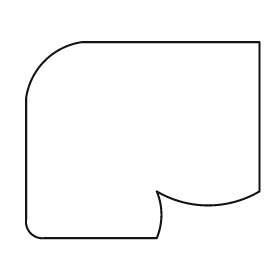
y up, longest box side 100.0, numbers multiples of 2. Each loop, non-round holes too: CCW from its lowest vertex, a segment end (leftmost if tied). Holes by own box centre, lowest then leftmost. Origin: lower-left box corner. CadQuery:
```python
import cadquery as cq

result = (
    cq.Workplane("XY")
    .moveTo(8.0, 0.0)
    .lineTo(56.0, 0.0)
    .threePointArc((58.0, 10.0), (56.0, 20.0))
    .threePointArc((78.0, 14.0), (100.0, 20.0))
    .lineTo(100.0, 84.0)
    .lineTo(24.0, 84.0)
    .threePointArc((8.0, 76.0), (0.0, 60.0))
    .lineTo(0.0, 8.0)
    .threePointArc((2.0, 2.0), (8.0, 0.0))
    .close()
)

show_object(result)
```